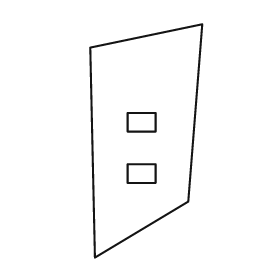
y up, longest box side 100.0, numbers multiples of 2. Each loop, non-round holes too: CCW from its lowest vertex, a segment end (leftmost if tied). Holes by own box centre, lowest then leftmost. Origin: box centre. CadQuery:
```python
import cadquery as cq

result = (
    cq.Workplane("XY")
    .moveTo(-22.0, -50.0)
    .lineTo(18.0, -26.0)
    .lineTo(24.0, 50.0)
    .lineTo(-24.0, 40.0)
    .close()
    .moveTo(-8.0, -18.0)
    .lineTo(4.0, -18.0)
    .lineTo(4.0, -10.0)
    .lineTo(-8.0, -10.0)
    .close()
    .moveTo(-8.0, 4.0)
    .lineTo(4.0, 4.0)
    .lineTo(4.0, 12.0)
    .lineTo(-8.0, 12.0)
    .close()
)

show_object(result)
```